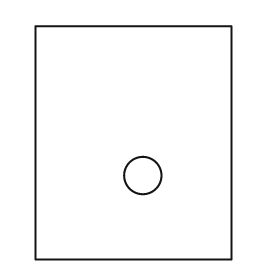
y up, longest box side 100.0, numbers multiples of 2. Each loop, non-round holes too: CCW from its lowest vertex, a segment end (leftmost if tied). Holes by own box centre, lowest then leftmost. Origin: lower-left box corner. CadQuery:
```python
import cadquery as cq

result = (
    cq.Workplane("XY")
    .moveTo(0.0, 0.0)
    .lineTo(84.0, 0.0)
    .lineTo(84.0, 100.0)
    .lineTo(0.0, 100.0)
    .close()
    .moveTo(46.0, 36.0)
    .circle(8.0)
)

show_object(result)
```